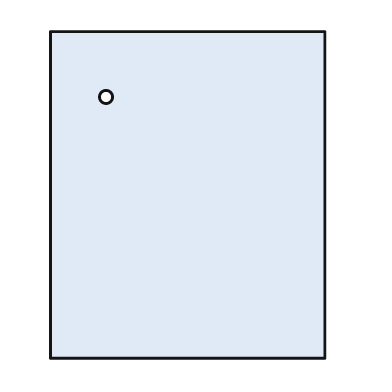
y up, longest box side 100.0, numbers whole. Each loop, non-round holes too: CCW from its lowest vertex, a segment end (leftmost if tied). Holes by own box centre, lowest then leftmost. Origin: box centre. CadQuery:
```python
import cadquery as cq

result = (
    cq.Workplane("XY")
    .moveTo(-42.0, -50.0)
    .lineTo(42.0, -50.0)
    .lineTo(42.0, 50.0)
    .lineTo(-42.0, 50.0)
    .close()
    .moveTo(-25.0, 30.0)
    .circle(2.0)
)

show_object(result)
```